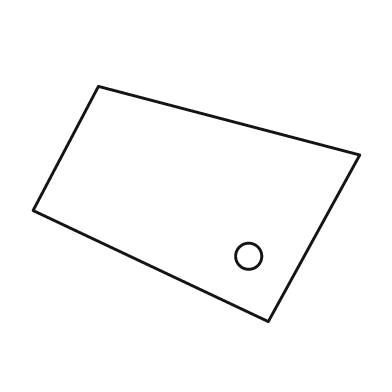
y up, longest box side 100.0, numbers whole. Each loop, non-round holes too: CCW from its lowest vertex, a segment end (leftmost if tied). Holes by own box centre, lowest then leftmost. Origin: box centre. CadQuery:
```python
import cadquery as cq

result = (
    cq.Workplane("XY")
    .moveTo(22.0, -36.0)
    .lineTo(50.0, 15.0)
    .lineTo(-30.0, 36.0)
    .lineTo(-50.0, -2.0)
    .close()
    .moveTo(16.0, -16.0)
    .circle(4.0)
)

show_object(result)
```